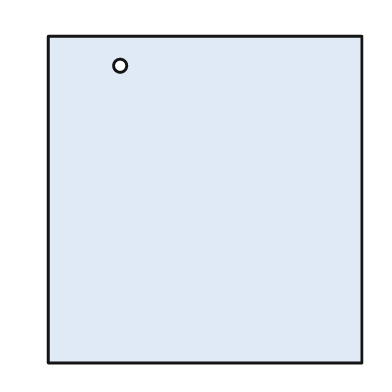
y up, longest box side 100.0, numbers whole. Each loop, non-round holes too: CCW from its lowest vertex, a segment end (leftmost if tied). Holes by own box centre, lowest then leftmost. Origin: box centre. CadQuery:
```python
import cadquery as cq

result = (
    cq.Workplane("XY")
    .moveTo(-48.0, -50.0)
    .lineTo(48.0, -50.0)
    .lineTo(48.0, 50.0)
    .lineTo(-48.0, 50.0)
    .close()
    .moveTo(-26.0, 41.0)
    .circle(2.0)
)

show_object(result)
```